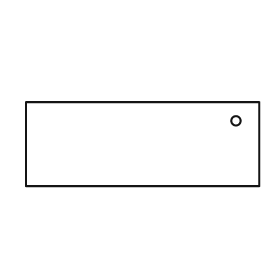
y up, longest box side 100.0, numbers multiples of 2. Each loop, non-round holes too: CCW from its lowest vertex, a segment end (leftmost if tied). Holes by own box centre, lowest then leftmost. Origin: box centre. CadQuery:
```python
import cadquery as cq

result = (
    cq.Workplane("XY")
    .moveTo(-50.0, -18.0)
    .lineTo(50.0, -18.0)
    .lineTo(50.0, 18.0)
    .lineTo(-50.0, 18.0)
    .close()
    .moveTo(40.0, 10.0)
    .circle(2.0)
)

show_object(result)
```